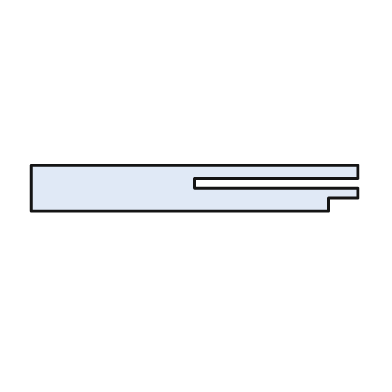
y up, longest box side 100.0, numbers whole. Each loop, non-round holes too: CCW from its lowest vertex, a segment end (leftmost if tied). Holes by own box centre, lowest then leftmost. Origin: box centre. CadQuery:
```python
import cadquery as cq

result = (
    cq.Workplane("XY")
    .moveTo(-50.0, -7.0)
    .lineTo(41.0, -7.0)
    .lineTo(41.0, -3.0)
    .lineTo(50.0, -3.0)
    .lineTo(50.0, 0.0)
    .lineTo(0.0, 0.0)
    .lineTo(0.0, 3.0)
    .lineTo(50.0, 3.0)
    .lineTo(50.0, 7.0)
    .lineTo(-50.0, 7.0)
    .close()
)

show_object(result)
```